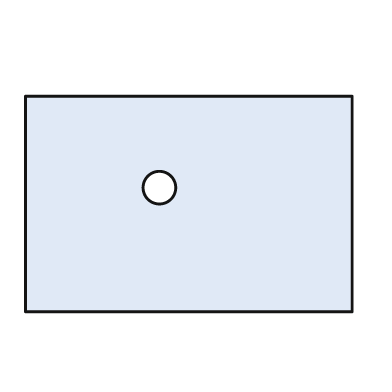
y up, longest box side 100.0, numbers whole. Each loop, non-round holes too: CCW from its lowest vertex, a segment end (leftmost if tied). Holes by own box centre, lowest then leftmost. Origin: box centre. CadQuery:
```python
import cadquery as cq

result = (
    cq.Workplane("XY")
    .moveTo(-50.0, -33.0)
    .lineTo(50.0, -33.0)
    .lineTo(50.0, 33.0)
    .lineTo(-50.0, 33.0)
    .close()
    .moveTo(-9.0, 5.0)
    .circle(5.0)
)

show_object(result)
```